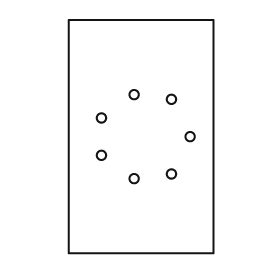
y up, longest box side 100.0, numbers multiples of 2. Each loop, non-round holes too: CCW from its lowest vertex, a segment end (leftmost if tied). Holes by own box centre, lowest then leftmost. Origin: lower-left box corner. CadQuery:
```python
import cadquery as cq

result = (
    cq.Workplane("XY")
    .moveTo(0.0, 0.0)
    .lineTo(62.0, 0.0)
    .lineTo(62.0, 100.0)
    .lineTo(0.0, 100.0)
    .close()
    .moveTo(28.0, 32.0)
    .circle(2.0)
    .moveTo(44.0, 34.0)
    .circle(2.0)
    .moveTo(14.0, 42.0)
    .circle(2.0)
    .moveTo(52.0, 50.0)
    .circle(2.0)
    .moveTo(14.0, 58.0)
    .circle(2.0)
    .moveTo(44.0, 66.0)
    .circle(2.0)
    .moveTo(28.0, 68.0)
    .circle(2.0)
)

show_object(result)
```